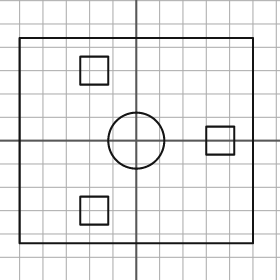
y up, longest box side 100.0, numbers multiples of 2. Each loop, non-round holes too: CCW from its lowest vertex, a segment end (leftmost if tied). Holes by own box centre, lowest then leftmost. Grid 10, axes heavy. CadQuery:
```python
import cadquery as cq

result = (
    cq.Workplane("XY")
    .moveTo(-50.0, -44.0)
    .lineTo(50.0, -44.0)
    .lineTo(50.0, 44.0)
    .lineTo(-50.0, 44.0)
    .close()
    .moveTo(-24.0, -36.0)
    .lineTo(-12.0, -36.0)
    .lineTo(-12.0, -24.0)
    .lineTo(-24.0, -24.0)
    .close()
    .moveTo(0.0, 0.0)
    .circle(12.0)
    .moveTo(30.0, -6.0)
    .lineTo(42.0, -6.0)
    .lineTo(42.0, 6.0)
    .lineTo(30.0, 6.0)
    .close()
    .moveTo(-24.0, 24.0)
    .lineTo(-12.0, 24.0)
    .lineTo(-12.0, 36.0)
    .lineTo(-24.0, 36.0)
    .close()
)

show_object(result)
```